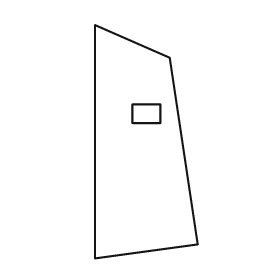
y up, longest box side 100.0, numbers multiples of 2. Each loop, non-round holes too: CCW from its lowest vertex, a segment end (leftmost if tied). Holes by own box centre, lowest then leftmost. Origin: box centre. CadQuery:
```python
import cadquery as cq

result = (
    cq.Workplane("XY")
    .moveTo(-22.0, -50.0)
    .lineTo(22.0, -44.0)
    .lineTo(10.0, 36.0)
    .lineTo(-22.0, 50.0)
    .close()
    .moveTo(-6.0, 8.0)
    .lineTo(6.0, 8.0)
    .lineTo(6.0, 16.0)
    .lineTo(-6.0, 16.0)
    .close()
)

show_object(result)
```